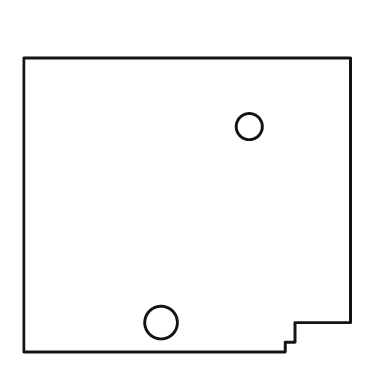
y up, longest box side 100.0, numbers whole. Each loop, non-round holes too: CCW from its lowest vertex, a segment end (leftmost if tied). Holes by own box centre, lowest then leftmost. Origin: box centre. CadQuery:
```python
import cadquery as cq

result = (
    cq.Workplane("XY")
    .moveTo(-50.0, -45.0)
    .lineTo(30.0, -45.0)
    .lineTo(30.0, -42.0)
    .lineTo(33.0, -42.0)
    .lineTo(33.0, -36.0)
    .lineTo(50.0, -36.0)
    .lineTo(50.0, 45.0)
    .lineTo(-50.0, 45.0)
    .close()
    .moveTo(-8.0, -36.0)
    .circle(5.0)
    .moveTo(19.0, 24.0)
    .circle(4.0)
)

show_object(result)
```